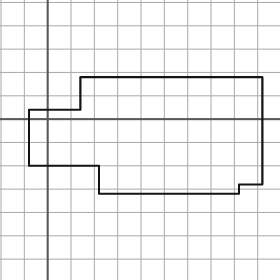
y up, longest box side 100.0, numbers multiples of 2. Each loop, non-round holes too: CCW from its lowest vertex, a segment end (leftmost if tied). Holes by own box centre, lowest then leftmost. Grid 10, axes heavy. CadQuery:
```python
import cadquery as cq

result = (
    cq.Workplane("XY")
    .moveTo(22.0, -32.0)
    .lineTo(82.0, -32.0)
    .lineTo(82.0, -28.0)
    .lineTo(92.0, -28.0)
    .lineTo(92.0, 18.0)
    .lineTo(14.0, 18.0)
    .lineTo(14.0, 4.0)
    .lineTo(-8.0, 4.0)
    .lineTo(-8.0, -20.0)
    .lineTo(22.0, -20.0)
    .close()
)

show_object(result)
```